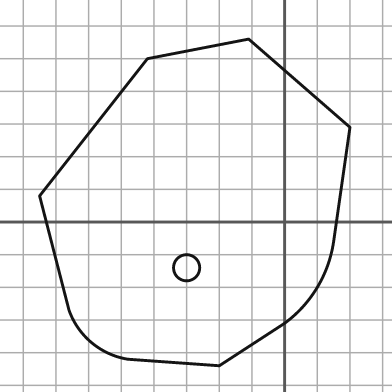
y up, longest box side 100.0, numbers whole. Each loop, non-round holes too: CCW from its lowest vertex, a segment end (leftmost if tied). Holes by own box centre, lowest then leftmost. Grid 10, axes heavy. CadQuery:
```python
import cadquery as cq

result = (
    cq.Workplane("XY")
    .moveTo(-20.0, -44.0)
    .lineTo(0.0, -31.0)
    .threePointArc((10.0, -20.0), (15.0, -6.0))
    .lineTo(20.0, 29.0)
    .lineTo(-11.0, 56.0)
    .lineTo(-42.0, 50.0)
    .lineTo(-75.0, 8.0)
    .lineTo(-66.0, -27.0)
    .threePointArc((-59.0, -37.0), (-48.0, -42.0))
    .close()
    .moveTo(-30.0, -14.0)
    .circle(4.0)
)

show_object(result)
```